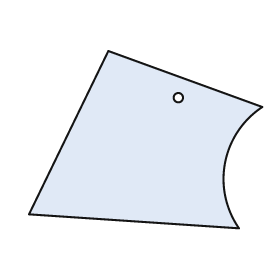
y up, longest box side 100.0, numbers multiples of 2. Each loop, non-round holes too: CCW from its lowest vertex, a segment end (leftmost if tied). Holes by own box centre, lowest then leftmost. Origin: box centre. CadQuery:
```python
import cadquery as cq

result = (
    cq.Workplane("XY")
    .moveTo(40.0, -38.0)
    .threePointArc((34.0, -10.0), (50.0, 14.0))
    .lineTo(-16.0, 38.0)
    .lineTo(-50.0, -32.0)
    .close()
    .moveTo(14.0, 18.0)
    .circle(2.0)
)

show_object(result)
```